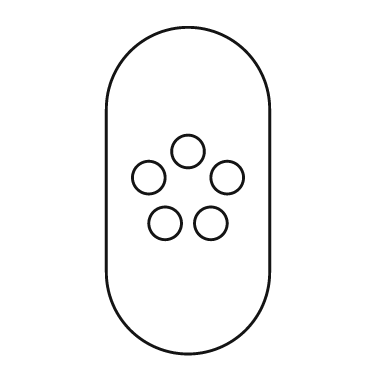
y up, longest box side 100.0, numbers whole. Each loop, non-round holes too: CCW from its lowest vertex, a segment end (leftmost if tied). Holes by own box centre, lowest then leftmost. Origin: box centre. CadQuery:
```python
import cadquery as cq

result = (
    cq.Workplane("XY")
    .moveTo(-25.0, -25.0)
    .threePointArc((0.0, -50.0), (25.0, -25.0))
    .lineTo(25.0, 25.0)
    .threePointArc((0.0, 50.0), (-25.0, 25.0))
    .close()
    .moveTo(-7.0, -10.0)
    .circle(5.0)
    .moveTo(7.0, -10.0)
    .circle(5.0)
    .moveTo(-12.0, 4.0)
    .circle(5.0)
    .moveTo(12.0, 4.0)
    .circle(5.0)
    .moveTo(0.0, 12.0)
    .circle(5.0)
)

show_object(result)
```